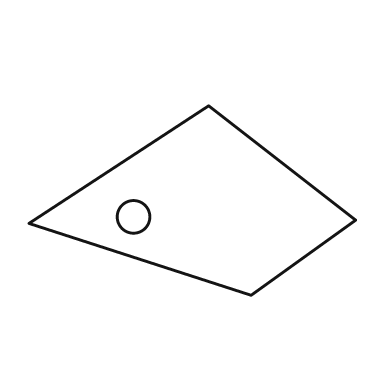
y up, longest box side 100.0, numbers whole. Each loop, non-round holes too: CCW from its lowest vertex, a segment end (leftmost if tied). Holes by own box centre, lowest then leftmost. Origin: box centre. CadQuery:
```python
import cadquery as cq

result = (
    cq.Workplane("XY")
    .moveTo(18.0, -29.0)
    .lineTo(50.0, -6.0)
    .lineTo(5.0, 29.0)
    .lineTo(-50.0, -7.0)
    .close()
    .moveTo(-18.0, -5.0)
    .circle(5.0)
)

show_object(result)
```